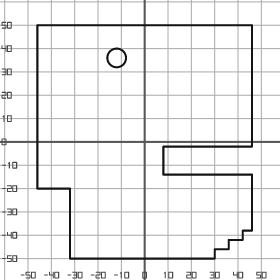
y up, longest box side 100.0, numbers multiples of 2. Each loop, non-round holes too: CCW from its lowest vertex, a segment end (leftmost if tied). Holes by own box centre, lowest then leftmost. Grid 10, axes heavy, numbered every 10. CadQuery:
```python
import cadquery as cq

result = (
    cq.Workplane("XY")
    .moveTo(-32.0, -50.0)
    .lineTo(30.0, -50.0)
    .lineTo(30.0, -46.0)
    .lineTo(36.0, -46.0)
    .lineTo(36.0, -42.0)
    .lineTo(42.0, -42.0)
    .lineTo(42.0, -38.0)
    .lineTo(46.0, -38.0)
    .lineTo(46.0, -14.0)
    .lineTo(8.0, -14.0)
    .lineTo(8.0, -2.0)
    .lineTo(46.0, -2.0)
    .lineTo(46.0, 50.0)
    .lineTo(-46.0, 50.0)
    .lineTo(-46.0, -20.0)
    .lineTo(-32.0, -20.0)
    .close()
    .moveTo(-12.0, 36.0)
    .circle(4.0)
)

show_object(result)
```